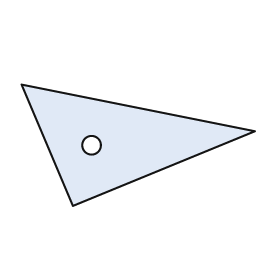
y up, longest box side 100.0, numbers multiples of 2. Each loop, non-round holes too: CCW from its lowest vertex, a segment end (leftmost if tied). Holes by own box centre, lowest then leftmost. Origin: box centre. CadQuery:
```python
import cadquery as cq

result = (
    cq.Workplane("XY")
    .moveTo(-28.0, -26.0)
    .lineTo(50.0, 6.0)
    .lineTo(-50.0, 26.0)
    .close()
    .moveTo(-20.0, 0.0)
    .circle(4.0)
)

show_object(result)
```